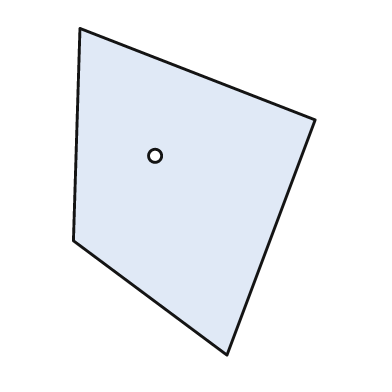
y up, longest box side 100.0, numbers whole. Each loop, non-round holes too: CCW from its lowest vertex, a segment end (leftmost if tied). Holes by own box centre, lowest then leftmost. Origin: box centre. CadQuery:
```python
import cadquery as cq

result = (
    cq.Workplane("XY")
    .moveTo(10.0, -50.0)
    .lineTo(37.0, 22.0)
    .lineTo(-35.0, 50.0)
    .lineTo(-37.0, -15.0)
    .close()
    .moveTo(-12.0, 11.0)
    .circle(2.0)
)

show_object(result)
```